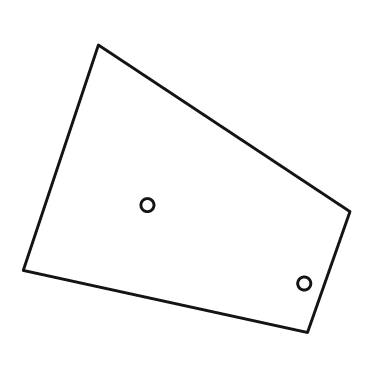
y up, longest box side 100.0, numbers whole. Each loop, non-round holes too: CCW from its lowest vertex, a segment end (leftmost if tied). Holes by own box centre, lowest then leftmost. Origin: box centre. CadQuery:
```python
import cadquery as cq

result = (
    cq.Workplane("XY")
    .moveTo(37.0, -44.0)
    .lineTo(50.0, -7.0)
    .lineTo(-27.0, 44.0)
    .lineTo(-50.0, -25.0)
    .close()
    .moveTo(36.0, -29.0)
    .circle(2.0)
    .moveTo(-12.0, -5.0)
    .circle(2.0)
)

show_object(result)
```